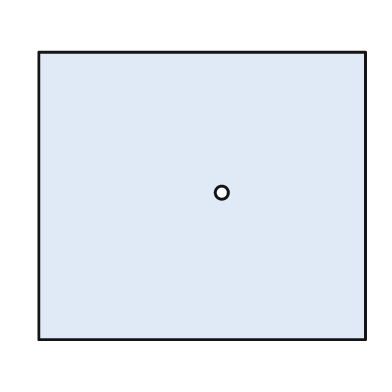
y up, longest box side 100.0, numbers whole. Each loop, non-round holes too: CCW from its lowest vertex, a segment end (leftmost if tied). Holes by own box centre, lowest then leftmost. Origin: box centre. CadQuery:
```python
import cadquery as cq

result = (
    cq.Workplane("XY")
    .moveTo(-50.0, -44.0)
    .lineTo(50.0, -44.0)
    .lineTo(50.0, 44.0)
    .lineTo(-50.0, 44.0)
    .close()
    .moveTo(6.0, 1.0)
    .circle(2.0)
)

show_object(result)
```